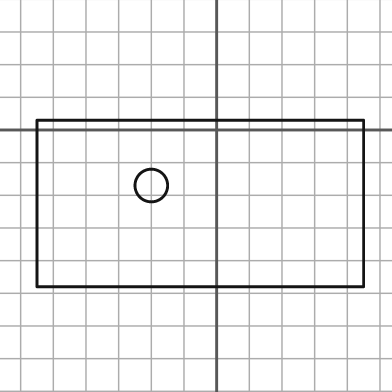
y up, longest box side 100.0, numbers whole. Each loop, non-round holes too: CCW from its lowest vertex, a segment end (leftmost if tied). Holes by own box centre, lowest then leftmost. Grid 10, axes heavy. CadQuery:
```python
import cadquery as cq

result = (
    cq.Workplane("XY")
    .moveTo(-55.0, -48.0)
    .lineTo(45.0, -48.0)
    .lineTo(45.0, 3.0)
    .lineTo(-55.0, 3.0)
    .close()
    .moveTo(-20.0, -17.0)
    .circle(5.0)
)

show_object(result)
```